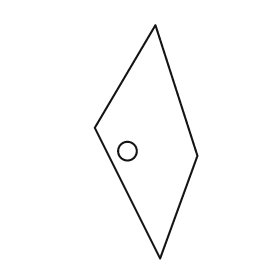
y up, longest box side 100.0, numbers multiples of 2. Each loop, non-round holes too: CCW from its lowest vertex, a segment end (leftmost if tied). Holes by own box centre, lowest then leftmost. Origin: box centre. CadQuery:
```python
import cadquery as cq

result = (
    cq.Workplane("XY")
    .moveTo(6.0, -50.0)
    .lineTo(22.0, -6.0)
    .lineTo(4.0, 50.0)
    .lineTo(-22.0, 6.0)
    .close()
    .moveTo(-8.0, -4.0)
    .circle(4.0)
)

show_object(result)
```